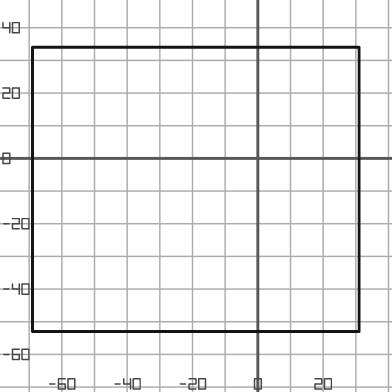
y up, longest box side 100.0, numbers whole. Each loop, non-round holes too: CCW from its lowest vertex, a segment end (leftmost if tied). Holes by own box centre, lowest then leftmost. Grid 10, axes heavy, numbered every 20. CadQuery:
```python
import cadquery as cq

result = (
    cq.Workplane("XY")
    .moveTo(-69.0, -53.0)
    .lineTo(31.0, -53.0)
    .lineTo(31.0, 34.0)
    .lineTo(-69.0, 34.0)
    .close()
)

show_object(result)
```